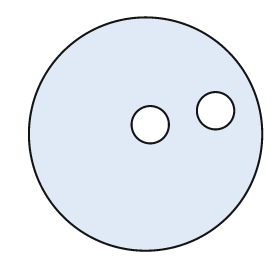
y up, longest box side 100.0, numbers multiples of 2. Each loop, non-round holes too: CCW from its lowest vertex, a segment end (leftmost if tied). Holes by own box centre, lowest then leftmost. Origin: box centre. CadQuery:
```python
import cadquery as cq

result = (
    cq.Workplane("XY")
    .moveTo(0.0, 0.0)
    .circle(50.0)
    .moveTo(2.0, 4.0)
    .circle(8.0)
    .moveTo(30.0, 10.0)
    .circle(8.0)
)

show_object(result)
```